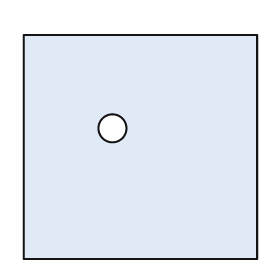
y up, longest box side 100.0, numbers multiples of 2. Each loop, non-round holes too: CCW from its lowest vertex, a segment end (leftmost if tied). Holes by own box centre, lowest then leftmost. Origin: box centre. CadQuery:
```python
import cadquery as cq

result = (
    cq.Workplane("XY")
    .moveTo(-50.0, -48.0)
    .lineTo(50.0, -48.0)
    .lineTo(50.0, 48.0)
    .lineTo(-50.0, 48.0)
    .close()
    .moveTo(-12.0, 8.0)
    .circle(6.0)
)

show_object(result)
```